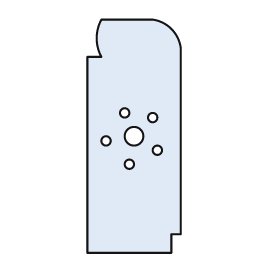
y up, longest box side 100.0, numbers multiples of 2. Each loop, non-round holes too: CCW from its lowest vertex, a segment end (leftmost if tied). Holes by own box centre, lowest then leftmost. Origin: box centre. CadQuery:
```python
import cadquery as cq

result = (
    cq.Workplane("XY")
    .moveTo(-20.0, -50.0)
    .lineTo(16.0, -50.0)
    .lineTo(16.0, -42.0)
    .lineTo(20.0, -42.0)
    .lineTo(20.0, 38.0)
    .threePointArc((16.0, 46.0), (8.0, 50.0))
    .lineTo(-14.0, 50.0)
    .threePointArc((-16.0, 42.0), (-14.0, 34.0))
    .lineTo(-20.0, 34.0)
    .close()
    .moveTo(-2.0, -12.0)
    .circle(2.0)
    .moveTo(10.0, -6.0)
    .circle(2.0)
    .moveTo(-12.0, -2.0)
    .circle(2.0)
    .moveTo(0.0, 0.0)
    .circle(4.0)
    .moveTo(8.0, 8.0)
    .circle(2.0)
    .moveTo(-4.0, 10.0)
    .circle(2.0)
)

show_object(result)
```